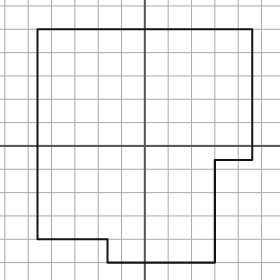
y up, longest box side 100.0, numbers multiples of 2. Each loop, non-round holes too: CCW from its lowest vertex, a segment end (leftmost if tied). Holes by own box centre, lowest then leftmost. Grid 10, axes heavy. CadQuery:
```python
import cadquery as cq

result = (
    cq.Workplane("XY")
    .moveTo(-16.0, -50.0)
    .lineTo(30.0, -50.0)
    .lineTo(30.0, -6.0)
    .lineTo(46.0, -6.0)
    .lineTo(46.0, 50.0)
    .lineTo(-46.0, 50.0)
    .lineTo(-46.0, -40.0)
    .lineTo(-16.0, -40.0)
    .close()
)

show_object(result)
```